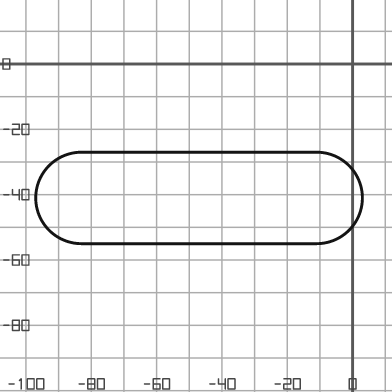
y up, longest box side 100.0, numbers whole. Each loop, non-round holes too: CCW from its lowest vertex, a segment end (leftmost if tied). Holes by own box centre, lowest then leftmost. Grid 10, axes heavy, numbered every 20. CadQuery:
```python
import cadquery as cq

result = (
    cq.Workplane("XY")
    .moveTo(-83.0, -55.0)
    .lineTo(-11.0, -55.0)
    .threePointArc((3.0, -41.0), (-11.0, -27.0))
    .lineTo(-83.0, -27.0)
    .threePointArc((-97.0, -41.0), (-83.0, -55.0))
    .close()
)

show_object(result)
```